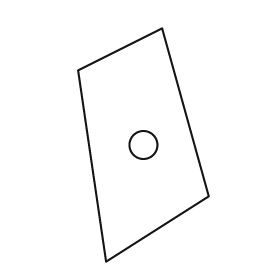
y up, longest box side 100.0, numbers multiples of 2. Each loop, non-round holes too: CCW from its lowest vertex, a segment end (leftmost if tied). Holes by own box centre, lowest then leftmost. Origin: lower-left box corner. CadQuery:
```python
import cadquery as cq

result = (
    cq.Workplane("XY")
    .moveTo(12.0, 0.0)
    .lineTo(56.0, 28.0)
    .lineTo(36.0, 100.0)
    .lineTo(0.0, 82.0)
    .close()
    .moveTo(28.0, 50.0)
    .circle(6.0)
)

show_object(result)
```